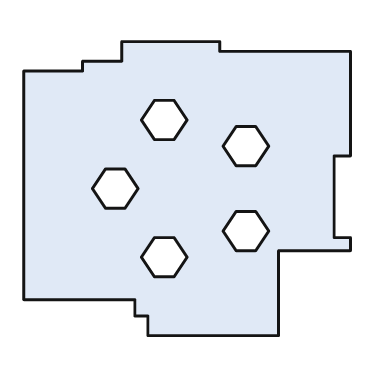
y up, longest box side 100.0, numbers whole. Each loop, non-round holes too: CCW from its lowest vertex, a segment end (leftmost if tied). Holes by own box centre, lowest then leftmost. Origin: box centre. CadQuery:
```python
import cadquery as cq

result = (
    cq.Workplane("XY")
    .moveTo(-12.0, -45.0)
    .lineTo(28.0, -45.0)
    .lineTo(28.0, -19.0)
    .lineTo(50.0, -19.0)
    .lineTo(50.0, -15.0)
    .lineTo(45.0, -15.0)
    .lineTo(45.0, 10.0)
    .lineTo(50.0, 10.0)
    .lineTo(50.0, 42.0)
    .lineTo(10.0, 42.0)
    .lineTo(10.0, 45.0)
    .lineTo(-20.0, 45.0)
    .lineTo(-20.0, 39.0)
    .lineTo(-32.0, 39.0)
    .lineTo(-32.0, 36.0)
    .lineTo(-50.0, 36.0)
    .lineTo(-50.0, -34.0)
    .lineTo(-16.0, -34.0)
    .lineTo(-16.0, -39.0)
    .lineTo(-12.0, -39.0)
    .close()
    .moveTo(-10.0, -27.0)
    .lineTo(-4.0, -27.0)
    .lineTo(0.0, -21.0)
    .lineTo(-4.0, -15.0)
    .lineTo(-10.0, -15.0)
    .lineTo(-14.0, -21.0)
    .close()
    .moveTo(15.0, -19.0)
    .lineTo(21.0, -19.0)
    .lineTo(25.0, -13.0)
    .lineTo(21.0, -7.0)
    .lineTo(15.0, -7.0)
    .lineTo(11.0, -13.0)
    .close()
    .moveTo(-25.0, -6.0)
    .lineTo(-19.0, -6.0)
    .lineTo(-15.0, 0.0)
    .lineTo(-19.0, 6.0)
    .lineTo(-25.0, 6.0)
    .lineTo(-29.0, 0.0)
    .close()
    .moveTo(15.0, 7.0)
    .lineTo(21.0, 7.0)
    .lineTo(25.0, 13.0)
    .lineTo(21.0, 19.0)
    .lineTo(15.0, 19.0)
    .lineTo(11.0, 13.0)
    .close()
    .moveTo(-10.0, 15.0)
    .lineTo(-4.0, 15.0)
    .lineTo(0.0, 21.0)
    .lineTo(-4.0, 27.0)
    .lineTo(-10.0, 27.0)
    .lineTo(-14.0, 21.0)
    .close()
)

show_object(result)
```